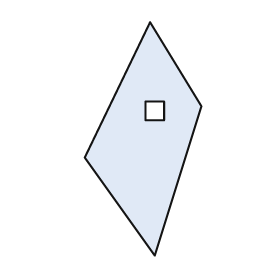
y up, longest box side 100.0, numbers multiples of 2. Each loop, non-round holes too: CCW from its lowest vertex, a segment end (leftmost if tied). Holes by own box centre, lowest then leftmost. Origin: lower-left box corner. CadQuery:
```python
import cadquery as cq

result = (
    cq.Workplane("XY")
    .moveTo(30.0, 0.0)
    .lineTo(50.0, 64.0)
    .lineTo(28.0, 100.0)
    .lineTo(0.0, 42.0)
    .close()
    .moveTo(26.0, 58.0)
    .lineTo(34.0, 58.0)
    .lineTo(34.0, 66.0)
    .lineTo(26.0, 66.0)
    .close()
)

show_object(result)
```